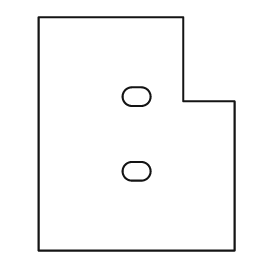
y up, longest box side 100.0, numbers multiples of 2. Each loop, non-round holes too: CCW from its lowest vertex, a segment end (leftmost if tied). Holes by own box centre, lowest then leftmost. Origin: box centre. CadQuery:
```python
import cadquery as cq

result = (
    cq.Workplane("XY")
    .moveTo(-42.0, -50.0)
    .lineTo(42.0, -50.0)
    .lineTo(42.0, 14.0)
    .lineTo(20.0, 14.0)
    .lineTo(20.0, 50.0)
    .lineTo(-42.0, 50.0)
    .close()
    .moveTo(-2.0, -20.0)
    .lineTo(2.0, -20.0)
    .threePointArc((6.0, -16.0), (2.0, -12.0))
    .lineTo(-2.0, -12.0)
    .threePointArc((-6.0, -16.0), (-2.0, -20.0))
    .close()
    .moveTo(-2.0, 12.0)
    .lineTo(2.0, 12.0)
    .threePointArc((6.0, 16.0), (2.0, 20.0))
    .lineTo(-2.0, 20.0)
    .threePointArc((-6.0, 16.0), (-2.0, 12.0))
    .close()
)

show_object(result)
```